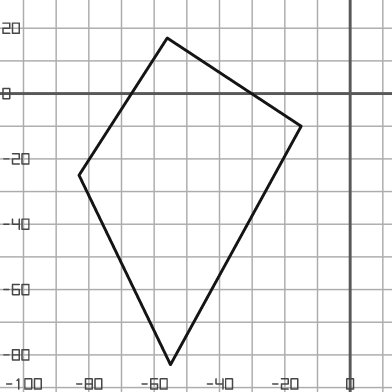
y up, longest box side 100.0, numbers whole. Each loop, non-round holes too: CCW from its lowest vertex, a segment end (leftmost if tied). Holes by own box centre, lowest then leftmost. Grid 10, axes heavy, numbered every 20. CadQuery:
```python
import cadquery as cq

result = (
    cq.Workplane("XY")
    .moveTo(-55.0, -83.0)
    .lineTo(-15.0, -10.0)
    .lineTo(-56.0, 17.0)
    .lineTo(-83.0, -25.0)
    .close()
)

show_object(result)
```